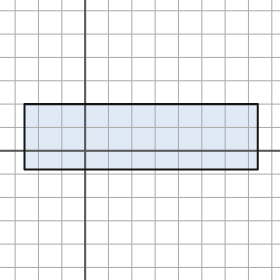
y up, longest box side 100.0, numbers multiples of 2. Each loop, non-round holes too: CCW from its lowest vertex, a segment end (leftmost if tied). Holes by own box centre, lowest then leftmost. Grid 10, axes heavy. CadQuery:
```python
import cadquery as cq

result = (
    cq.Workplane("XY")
    .moveTo(-26.0, -8.0)
    .lineTo(74.0, -8.0)
    .lineTo(74.0, 20.0)
    .lineTo(-26.0, 20.0)
    .close()
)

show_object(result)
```